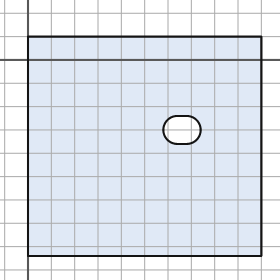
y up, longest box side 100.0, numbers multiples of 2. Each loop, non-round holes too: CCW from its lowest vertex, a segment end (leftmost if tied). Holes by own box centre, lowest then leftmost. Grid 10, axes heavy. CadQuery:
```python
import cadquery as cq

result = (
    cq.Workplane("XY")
    .moveTo(0.0, -84.0)
    .lineTo(100.0, -84.0)
    .lineTo(100.0, 10.0)
    .lineTo(0.0, 10.0)
    .close()
    .moveTo(64.0, -36.0)
    .lineTo(68.0, -36.0)
    .threePointArc((74.0, -30.0), (68.0, -24.0))
    .lineTo(64.0, -24.0)
    .threePointArc((58.0, -30.0), (64.0, -36.0))
    .close()
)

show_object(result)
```